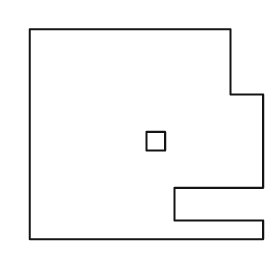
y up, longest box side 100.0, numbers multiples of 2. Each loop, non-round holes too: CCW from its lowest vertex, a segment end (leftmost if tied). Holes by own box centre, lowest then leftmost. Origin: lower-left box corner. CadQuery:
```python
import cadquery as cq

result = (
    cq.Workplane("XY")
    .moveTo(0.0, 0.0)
    .lineTo(100.0, 0.0)
    .lineTo(100.0, 8.0)
    .lineTo(62.0, 8.0)
    .lineTo(62.0, 22.0)
    .lineTo(100.0, 22.0)
    .lineTo(100.0, 62.0)
    .lineTo(86.0, 62.0)
    .lineTo(86.0, 90.0)
    .lineTo(0.0, 90.0)
    .close()
    .moveTo(50.0, 38.0)
    .lineTo(58.0, 38.0)
    .lineTo(58.0, 46.0)
    .lineTo(50.0, 46.0)
    .close()
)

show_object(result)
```